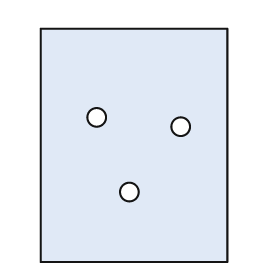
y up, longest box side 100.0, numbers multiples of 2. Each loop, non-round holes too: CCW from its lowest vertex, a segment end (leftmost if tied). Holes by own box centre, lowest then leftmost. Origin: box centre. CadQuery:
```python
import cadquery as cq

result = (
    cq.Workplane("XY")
    .moveTo(-40.0, -50.0)
    .lineTo(40.0, -50.0)
    .lineTo(40.0, 50.0)
    .lineTo(-40.0, 50.0)
    .close()
    .moveTo(-2.0, -20.0)
    .circle(4.0)
    .moveTo(20.0, 8.0)
    .circle(4.0)
    .moveTo(-16.0, 12.0)
    .circle(4.0)
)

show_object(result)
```